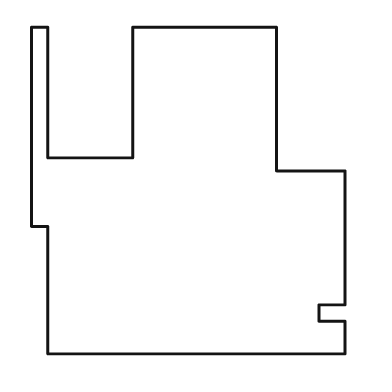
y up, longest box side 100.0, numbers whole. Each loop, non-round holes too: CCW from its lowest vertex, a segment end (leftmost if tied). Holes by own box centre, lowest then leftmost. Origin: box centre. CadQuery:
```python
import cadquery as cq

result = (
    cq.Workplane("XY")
    .moveTo(-43.0, -50.0)
    .lineTo(48.0, -50.0)
    .lineTo(48.0, -40.0)
    .lineTo(40.0, -40.0)
    .lineTo(40.0, -35.0)
    .lineTo(48.0, -35.0)
    .lineTo(48.0, 6.0)
    .lineTo(27.0, 6.0)
    .lineTo(27.0, 50.0)
    .lineTo(-17.0, 50.0)
    .lineTo(-17.0, 10.0)
    .lineTo(-43.0, 10.0)
    .lineTo(-43.0, 50.0)
    .lineTo(-48.0, 50.0)
    .lineTo(-48.0, -11.0)
    .lineTo(-43.0, -11.0)
    .close()
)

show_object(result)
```